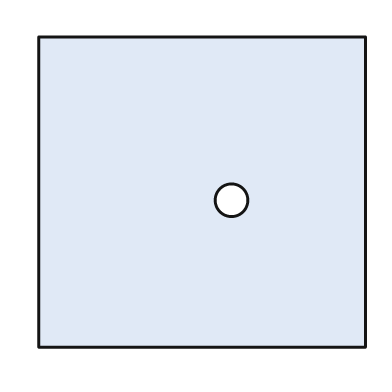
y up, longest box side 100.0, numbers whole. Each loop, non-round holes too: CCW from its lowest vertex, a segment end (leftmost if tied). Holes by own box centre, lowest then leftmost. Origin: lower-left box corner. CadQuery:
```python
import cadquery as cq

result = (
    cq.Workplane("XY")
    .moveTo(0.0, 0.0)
    .lineTo(100.0, 0.0)
    .lineTo(100.0, 95.0)
    .lineTo(0.0, 95.0)
    .close()
    .moveTo(59.0, 45.0)
    .circle(5.0)
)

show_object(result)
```